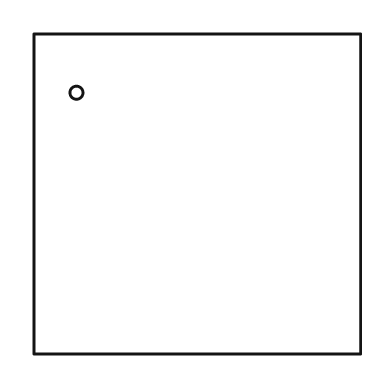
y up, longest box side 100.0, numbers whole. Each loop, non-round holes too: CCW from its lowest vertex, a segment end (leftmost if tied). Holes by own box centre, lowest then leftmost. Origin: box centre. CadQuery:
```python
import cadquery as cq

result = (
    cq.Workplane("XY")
    .moveTo(-50.0, -49.0)
    .lineTo(50.0, -49.0)
    .lineTo(50.0, 49.0)
    .lineTo(-50.0, 49.0)
    .close()
    .moveTo(-37.0, 31.0)
    .circle(2.0)
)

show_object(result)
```